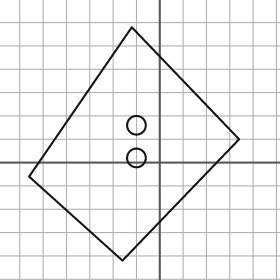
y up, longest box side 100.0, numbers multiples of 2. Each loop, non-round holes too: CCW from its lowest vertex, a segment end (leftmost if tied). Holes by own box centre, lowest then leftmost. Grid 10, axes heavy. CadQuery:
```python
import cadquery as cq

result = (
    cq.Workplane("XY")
    .moveTo(-16.0, -42.0)
    .lineTo(34.0, 10.0)
    .lineTo(-12.0, 58.0)
    .lineTo(-56.0, -6.0)
    .close()
    .moveTo(-10.0, 2.0)
    .circle(4.0)
    .moveTo(-10.0, 16.0)
    .circle(4.0)
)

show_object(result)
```